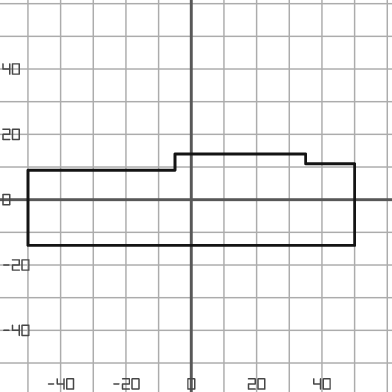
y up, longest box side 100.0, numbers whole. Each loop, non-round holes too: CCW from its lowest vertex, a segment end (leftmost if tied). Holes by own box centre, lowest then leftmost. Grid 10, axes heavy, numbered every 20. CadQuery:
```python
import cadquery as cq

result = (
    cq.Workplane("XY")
    .moveTo(-50.0, -14.0)
    .lineTo(50.0, -14.0)
    .lineTo(50.0, 11.0)
    .lineTo(35.0, 11.0)
    .lineTo(35.0, 14.0)
    .lineTo(-5.0, 14.0)
    .lineTo(-5.0, 9.0)
    .lineTo(-50.0, 9.0)
    .close()
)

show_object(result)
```